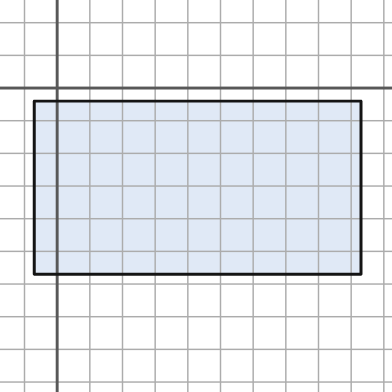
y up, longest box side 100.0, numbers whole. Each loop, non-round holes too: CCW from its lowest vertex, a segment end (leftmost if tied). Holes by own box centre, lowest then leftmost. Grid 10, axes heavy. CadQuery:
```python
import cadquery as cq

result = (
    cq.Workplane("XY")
    .moveTo(-7.0, -57.0)
    .lineTo(93.0, -57.0)
    .lineTo(93.0, -4.0)
    .lineTo(-7.0, -4.0)
    .close()
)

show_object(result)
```